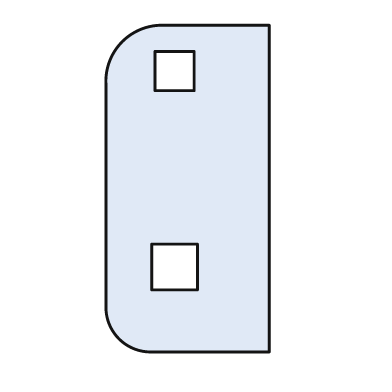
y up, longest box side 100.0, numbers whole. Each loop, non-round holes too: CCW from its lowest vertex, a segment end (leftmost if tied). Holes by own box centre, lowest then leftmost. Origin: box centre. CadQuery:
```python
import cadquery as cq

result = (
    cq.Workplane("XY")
    .moveTo(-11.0, -50.0)
    .lineTo(25.0, -50.0)
    .lineTo(25.0, 50.0)
    .lineTo(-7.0, 50.0)
    .threePointArc((-20.0, 45.0), (-25.0, 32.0))
    .lineTo(-25.0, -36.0)
    .threePointArc((-21.0, -46.0), (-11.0, -50.0))
    .close()
    .moveTo(-11.0, -31.0)
    .lineTo(3.0, -31.0)
    .lineTo(3.0, -17.0)
    .lineTo(-11.0, -17.0)
    .close()
    .moveTo(-10.0, 30.0)
    .lineTo(2.0, 30.0)
    .lineTo(2.0, 42.0)
    .lineTo(-10.0, 42.0)
    .close()
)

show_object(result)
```